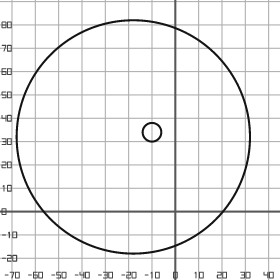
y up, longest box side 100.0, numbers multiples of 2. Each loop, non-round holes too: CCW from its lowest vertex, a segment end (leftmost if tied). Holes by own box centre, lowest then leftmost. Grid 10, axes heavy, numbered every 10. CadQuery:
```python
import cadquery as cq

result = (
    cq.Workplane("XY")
    .moveTo(-18.0, 32.0)
    .circle(50.0)
    .moveTo(-10.0, 34.0)
    .circle(4.0)
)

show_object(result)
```